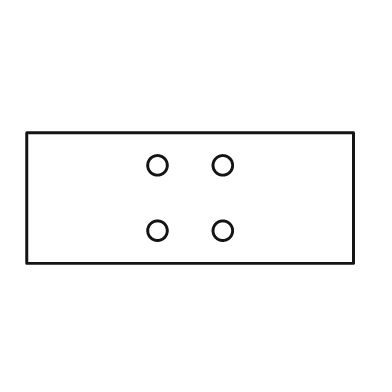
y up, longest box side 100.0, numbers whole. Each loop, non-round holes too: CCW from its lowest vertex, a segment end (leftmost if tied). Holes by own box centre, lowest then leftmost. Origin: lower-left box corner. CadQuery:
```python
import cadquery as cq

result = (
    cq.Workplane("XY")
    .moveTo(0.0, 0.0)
    .lineTo(100.0, 0.0)
    .lineTo(100.0, 40.0)
    .lineTo(0.0, 40.0)
    .close()
    .moveTo(40.0, 10.0)
    .circle(3.0)
    .moveTo(60.0, 10.0)
    .circle(3.0)
    .moveTo(40.0, 30.0)
    .circle(3.0)
    .moveTo(60.0, 30.0)
    .circle(3.0)
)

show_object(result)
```